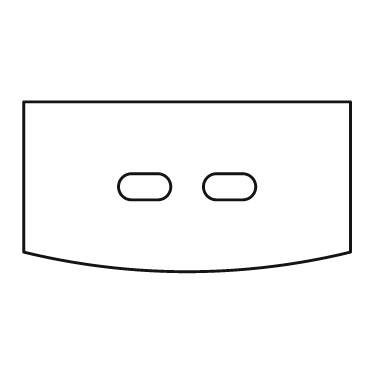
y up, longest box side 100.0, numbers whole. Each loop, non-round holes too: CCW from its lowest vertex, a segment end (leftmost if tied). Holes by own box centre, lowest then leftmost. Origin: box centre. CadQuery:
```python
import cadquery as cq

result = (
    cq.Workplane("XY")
    .moveTo(-50.0, -20.0)
    .threePointArc((0.0, -26.0), (50.0, -20.0))
    .lineTo(50.0, 26.0)
    .lineTo(-50.0, 26.0)
    .close()
    .moveTo(-17.0, -4.0)
    .lineTo(-9.0, -4.0)
    .threePointArc((-5.0, 0.0), (-9.0, 4.0))
    .lineTo(-17.0, 4.0)
    .threePointArc((-21.0, 0.0), (-17.0, -4.0))
    .close()
    .moveTo(9.0, -4.0)
    .lineTo(17.0, -4.0)
    .threePointArc((21.0, 0.0), (17.0, 4.0))
    .lineTo(9.0, 4.0)
    .threePointArc((5.0, 0.0), (9.0, -4.0))
    .close()
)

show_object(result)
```